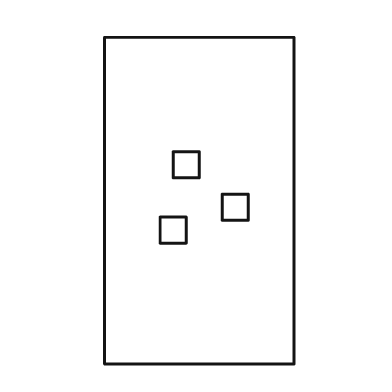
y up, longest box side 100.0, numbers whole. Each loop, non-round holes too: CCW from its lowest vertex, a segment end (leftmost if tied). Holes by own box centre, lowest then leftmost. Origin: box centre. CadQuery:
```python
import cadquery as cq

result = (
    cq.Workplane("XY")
    .moveTo(-29.0, -50.0)
    .lineTo(29.0, -50.0)
    .lineTo(29.0, 50.0)
    .lineTo(-29.0, 50.0)
    .close()
    .moveTo(-12.0, -13.0)
    .lineTo(-4.0, -13.0)
    .lineTo(-4.0, -5.0)
    .lineTo(-12.0, -5.0)
    .close()
    .moveTo(7.0, -6.0)
    .lineTo(15.0, -6.0)
    .lineTo(15.0, 2.0)
    .lineTo(7.0, 2.0)
    .close()
    .moveTo(-8.0, 7.0)
    .lineTo(0.0, 7.0)
    .lineTo(0.0, 15.0)
    .lineTo(-8.0, 15.0)
    .close()
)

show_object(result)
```